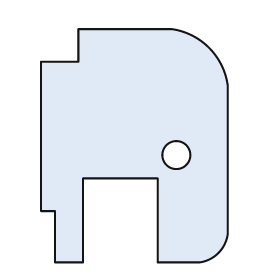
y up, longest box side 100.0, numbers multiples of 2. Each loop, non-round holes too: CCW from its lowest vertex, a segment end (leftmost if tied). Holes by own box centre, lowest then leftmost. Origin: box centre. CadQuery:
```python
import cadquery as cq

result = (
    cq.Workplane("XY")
    .moveTo(-34.0, -50.0)
    .lineTo(-22.0, -50.0)
    .lineTo(-22.0, -14.0)
    .lineTo(10.0, -14.0)
    .lineTo(10.0, -50.0)
    .lineTo(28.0, -50.0)
    .threePointArc((36.0, -46.0), (40.0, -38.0))
    .lineTo(40.0, 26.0)
    .threePointArc((32.0, 42.0), (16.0, 50.0))
    .lineTo(-24.0, 50.0)
    .lineTo(-24.0, 36.0)
    .lineTo(-40.0, 36.0)
    .lineTo(-40.0, -28.0)
    .lineTo(-34.0, -28.0)
    .close()
    .moveTo(18.0, -4.0)
    .circle(6.0)
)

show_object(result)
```